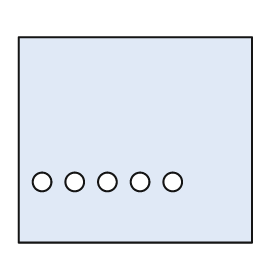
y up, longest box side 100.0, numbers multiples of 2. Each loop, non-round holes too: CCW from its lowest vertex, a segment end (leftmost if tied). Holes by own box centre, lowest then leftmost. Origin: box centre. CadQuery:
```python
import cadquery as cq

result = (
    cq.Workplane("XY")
    .moveTo(-50.0, -44.0)
    .lineTo(50.0, -44.0)
    .lineTo(50.0, 44.0)
    .lineTo(-50.0, 44.0)
    .close()
    .moveTo(-40.0, -18.0)
    .circle(4.0)
    .moveTo(-26.0, -18.0)
    .circle(4.0)
    .moveTo(-12.0, -18.0)
    .circle(4.0)
    .moveTo(2.0, -18.0)
    .circle(4.0)
    .moveTo(16.0, -18.0)
    .circle(4.0)
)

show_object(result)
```